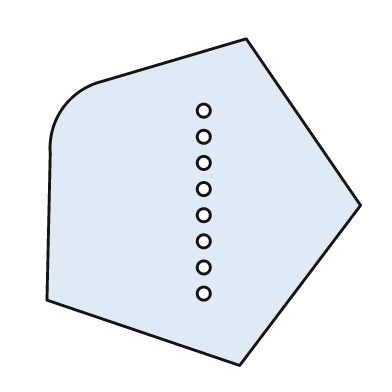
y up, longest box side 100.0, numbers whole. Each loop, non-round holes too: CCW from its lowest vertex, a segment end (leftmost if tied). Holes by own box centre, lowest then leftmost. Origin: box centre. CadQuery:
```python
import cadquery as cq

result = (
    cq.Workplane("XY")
    .moveTo(11.0, -50.0)
    .lineTo(48.0, -1.0)
    .lineTo(13.0, 50.0)
    .lineTo(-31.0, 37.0)
    .threePointArc((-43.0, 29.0), (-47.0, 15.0))
    .lineTo(-48.0, -30.0)
    .close()
    .moveTo(0.0, -28.0)
    .circle(2.0)
    .moveTo(0.0, -20.0)
    .circle(2.0)
    .moveTo(0.0, -12.0)
    .circle(2.0)
    .moveTo(0.0, -4.0)
    .circle(2.0)
    .moveTo(0.0, 4.0)
    .circle(2.0)
    .moveTo(0.0, 12.0)
    .circle(2.0)
    .moveTo(0.0, 20.0)
    .circle(2.0)
    .moveTo(0.0, 28.0)
    .circle(2.0)
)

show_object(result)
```